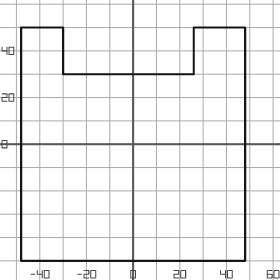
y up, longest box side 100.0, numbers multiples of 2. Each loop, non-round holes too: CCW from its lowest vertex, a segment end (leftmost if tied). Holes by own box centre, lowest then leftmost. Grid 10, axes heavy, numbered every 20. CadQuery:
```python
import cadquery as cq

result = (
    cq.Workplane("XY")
    .moveTo(-48.0, -50.0)
    .lineTo(48.0, -50.0)
    .lineTo(48.0, 50.0)
    .lineTo(26.0, 50.0)
    .lineTo(26.0, 30.0)
    .lineTo(-30.0, 30.0)
    .lineTo(-30.0, 50.0)
    .lineTo(-48.0, 50.0)
    .close()
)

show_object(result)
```